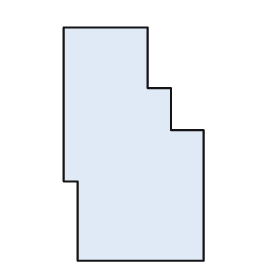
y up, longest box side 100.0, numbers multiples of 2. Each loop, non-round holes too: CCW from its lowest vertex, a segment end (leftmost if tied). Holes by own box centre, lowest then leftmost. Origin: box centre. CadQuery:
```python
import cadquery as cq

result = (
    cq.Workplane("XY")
    .moveTo(-24.0, -50.0)
    .lineTo(30.0, -50.0)
    .lineTo(30.0, 6.0)
    .lineTo(16.0, 6.0)
    .lineTo(16.0, 24.0)
    .lineTo(6.0, 24.0)
    .lineTo(6.0, 50.0)
    .lineTo(-30.0, 50.0)
    .lineTo(-30.0, -16.0)
    .lineTo(-24.0, -16.0)
    .close()
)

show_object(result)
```